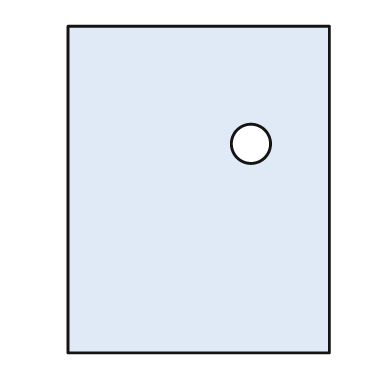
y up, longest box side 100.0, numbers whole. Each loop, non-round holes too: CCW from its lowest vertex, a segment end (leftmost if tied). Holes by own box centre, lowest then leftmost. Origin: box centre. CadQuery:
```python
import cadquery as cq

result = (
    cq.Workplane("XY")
    .moveTo(-40.0, -50.0)
    .lineTo(40.0, -50.0)
    .lineTo(40.0, 50.0)
    .lineTo(-40.0, 50.0)
    .close()
    .moveTo(16.0, 14.0)
    .circle(6.0)
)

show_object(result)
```